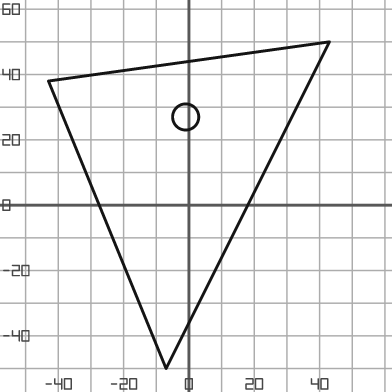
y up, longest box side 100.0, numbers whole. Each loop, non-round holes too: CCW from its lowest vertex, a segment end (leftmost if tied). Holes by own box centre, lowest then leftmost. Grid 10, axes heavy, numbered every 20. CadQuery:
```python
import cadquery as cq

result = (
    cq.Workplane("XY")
    .moveTo(-7.0, -50.0)
    .lineTo(43.0, 50.0)
    .lineTo(-43.0, 38.0)
    .close()
    .moveTo(-1.0, 27.0)
    .circle(4.0)
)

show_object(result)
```